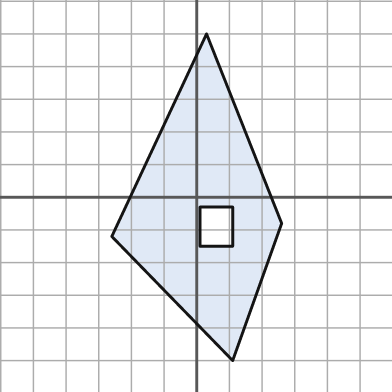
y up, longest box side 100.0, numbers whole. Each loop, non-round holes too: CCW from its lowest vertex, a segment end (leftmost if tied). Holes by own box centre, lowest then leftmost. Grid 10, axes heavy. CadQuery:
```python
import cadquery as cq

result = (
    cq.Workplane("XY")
    .moveTo(11.0, -50.0)
    .lineTo(26.0, -8.0)
    .lineTo(3.0, 50.0)
    .lineTo(-26.0, -12.0)
    .close()
    .moveTo(1.0, -15.0)
    .lineTo(11.0, -15.0)
    .lineTo(11.0, -3.0)
    .lineTo(1.0, -3.0)
    .close()
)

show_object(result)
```